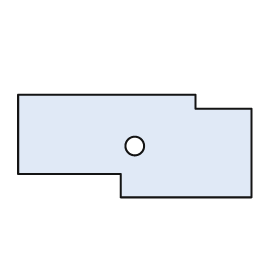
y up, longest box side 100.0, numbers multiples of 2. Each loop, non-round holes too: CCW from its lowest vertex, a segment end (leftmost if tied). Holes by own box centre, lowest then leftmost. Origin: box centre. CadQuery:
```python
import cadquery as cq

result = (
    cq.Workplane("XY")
    .moveTo(-6.0, -22.0)
    .lineTo(50.0, -22.0)
    .lineTo(50.0, 16.0)
    .lineTo(26.0, 16.0)
    .lineTo(26.0, 22.0)
    .lineTo(-50.0, 22.0)
    .lineTo(-50.0, -12.0)
    .lineTo(-6.0, -12.0)
    .close()
    .moveTo(0.0, 0.0)
    .circle(4.0)
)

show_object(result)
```